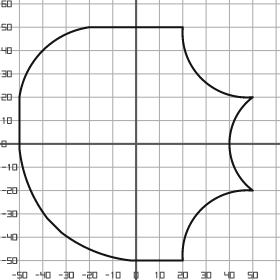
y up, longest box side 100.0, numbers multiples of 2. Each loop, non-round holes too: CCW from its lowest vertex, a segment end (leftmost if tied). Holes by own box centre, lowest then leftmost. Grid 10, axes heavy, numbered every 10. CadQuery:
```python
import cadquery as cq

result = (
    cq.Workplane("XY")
    .moveTo(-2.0, -50.0)
    .lineTo(20.0, -50.0)
    .threePointArc((28.0, -28.0), (50.0, -20.0))
    .threePointArc((40.0, 0.0), (50.0, 20.0))
    .threePointArc((28.0, 28.0), (20.0, 50.0))
    .lineTo(-20.0, 50.0)
    .threePointArc((-40.0, 40.0), (-50.0, 20.0))
    .lineTo(-50.0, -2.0)
    .threePointArc((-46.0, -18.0), (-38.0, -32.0))
    .lineTo(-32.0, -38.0)
    .threePointArc((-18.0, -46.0), (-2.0, -50.0))
    .close()
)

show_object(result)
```